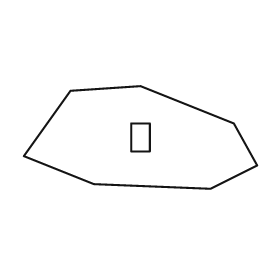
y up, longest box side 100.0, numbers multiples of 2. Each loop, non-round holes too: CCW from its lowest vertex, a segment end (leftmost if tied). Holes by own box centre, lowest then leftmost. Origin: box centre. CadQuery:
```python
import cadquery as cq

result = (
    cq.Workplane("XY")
    .moveTo(30.0, -22.0)
    .lineTo(50.0, -12.0)
    .lineTo(40.0, 6.0)
    .lineTo(0.0, 22.0)
    .lineTo(-30.0, 20.0)
    .lineTo(-50.0, -8.0)
    .lineTo(-20.0, -20.0)
    .close()
    .moveTo(-4.0, -6.0)
    .lineTo(4.0, -6.0)
    .lineTo(4.0, 6.0)
    .lineTo(-4.0, 6.0)
    .close()
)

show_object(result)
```